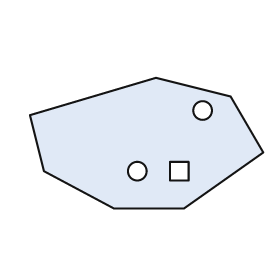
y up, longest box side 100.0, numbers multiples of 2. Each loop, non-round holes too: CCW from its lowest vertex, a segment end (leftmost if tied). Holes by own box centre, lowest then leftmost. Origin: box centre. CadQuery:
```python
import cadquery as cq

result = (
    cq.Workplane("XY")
    .moveTo(-14.0, -28.0)
    .lineTo(16.0, -28.0)
    .lineTo(50.0, -4.0)
    .lineTo(36.0, 20.0)
    .lineTo(4.0, 28.0)
    .lineTo(-50.0, 12.0)
    .lineTo(-44.0, -12.0)
    .close()
    .moveTo(-4.0, -12.0)
    .circle(4.0)
    .moveTo(10.0, -16.0)
    .lineTo(18.0, -16.0)
    .lineTo(18.0, -8.0)
    .lineTo(10.0, -8.0)
    .close()
    .moveTo(24.0, 14.0)
    .circle(4.0)
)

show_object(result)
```